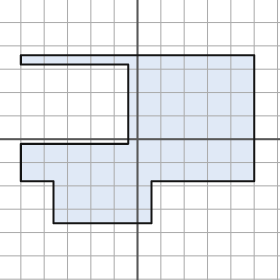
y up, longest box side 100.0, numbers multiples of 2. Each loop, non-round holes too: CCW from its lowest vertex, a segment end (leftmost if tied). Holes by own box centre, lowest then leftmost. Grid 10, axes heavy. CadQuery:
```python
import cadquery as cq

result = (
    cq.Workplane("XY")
    .moveTo(-36.0, -36.0)
    .lineTo(6.0, -36.0)
    .lineTo(6.0, -18.0)
    .lineTo(50.0, -18.0)
    .lineTo(50.0, 36.0)
    .lineTo(-50.0, 36.0)
    .lineTo(-50.0, 32.0)
    .lineTo(-4.0, 32.0)
    .lineTo(-4.0, -2.0)
    .lineTo(-50.0, -2.0)
    .lineTo(-50.0, -18.0)
    .lineTo(-36.0, -18.0)
    .close()
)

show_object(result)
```